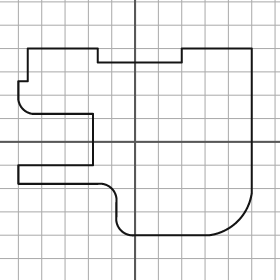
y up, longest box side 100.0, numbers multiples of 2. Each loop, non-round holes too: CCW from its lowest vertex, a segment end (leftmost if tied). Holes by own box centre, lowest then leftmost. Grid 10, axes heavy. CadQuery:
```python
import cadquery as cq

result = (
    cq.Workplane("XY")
    .moveTo(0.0, -40.0)
    .lineTo(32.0, -40.0)
    .threePointArc((44.0, -34.0), (50.0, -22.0))
    .lineTo(50.0, 40.0)
    .lineTo(20.0, 40.0)
    .lineTo(20.0, 34.0)
    .lineTo(-16.0, 34.0)
    .lineTo(-16.0, 40.0)
    .lineTo(-46.0, 40.0)
    .lineTo(-46.0, 26.0)
    .lineTo(-50.0, 26.0)
    .lineTo(-50.0, 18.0)
    .threePointArc((-48.0, 14.0), (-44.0, 12.0))
    .lineTo(-18.0, 12.0)
    .lineTo(-18.0, -10.0)
    .lineTo(-50.0, -10.0)
    .lineTo(-50.0, -18.0)
    .lineTo(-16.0, -18.0)
    .threePointArc((-10.0, -20.0), (-8.0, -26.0))
    .lineTo(-8.0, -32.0)
    .threePointArc((-6.0, -38.0), (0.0, -40.0))
    .close()
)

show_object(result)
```